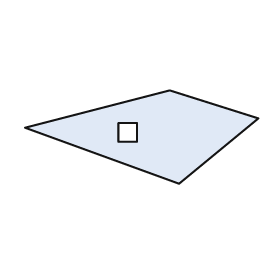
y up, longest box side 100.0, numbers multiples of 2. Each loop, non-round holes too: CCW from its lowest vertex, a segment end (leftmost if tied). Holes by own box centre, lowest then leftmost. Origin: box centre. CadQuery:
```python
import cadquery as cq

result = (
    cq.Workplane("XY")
    .moveTo(16.0, -20.0)
    .lineTo(50.0, 8.0)
    .lineTo(12.0, 20.0)
    .lineTo(-50.0, 4.0)
    .close()
    .moveTo(-10.0, -2.0)
    .lineTo(-2.0, -2.0)
    .lineTo(-2.0, 6.0)
    .lineTo(-10.0, 6.0)
    .close()
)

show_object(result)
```